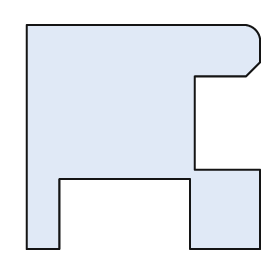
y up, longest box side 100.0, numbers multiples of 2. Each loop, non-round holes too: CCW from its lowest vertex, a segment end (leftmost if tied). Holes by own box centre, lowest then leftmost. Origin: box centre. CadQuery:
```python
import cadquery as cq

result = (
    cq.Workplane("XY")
    .moveTo(-50.0, -48.0)
    .lineTo(-36.0, -48.0)
    .lineTo(-36.0, -18.0)
    .lineTo(20.0, -18.0)
    .lineTo(20.0, -48.0)
    .lineTo(50.0, -48.0)
    .lineTo(50.0, -14.0)
    .lineTo(22.0, -14.0)
    .lineTo(22.0, 26.0)
    .lineTo(44.0, 26.0)
    .lineTo(50.0, 32.0)
    .lineTo(50.0, 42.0)
    .threePointArc((48.0, 46.0), (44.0, 48.0))
    .lineTo(-50.0, 48.0)
    .close()
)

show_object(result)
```